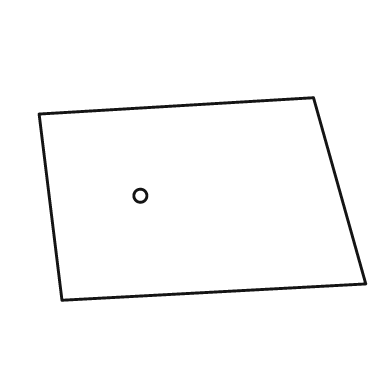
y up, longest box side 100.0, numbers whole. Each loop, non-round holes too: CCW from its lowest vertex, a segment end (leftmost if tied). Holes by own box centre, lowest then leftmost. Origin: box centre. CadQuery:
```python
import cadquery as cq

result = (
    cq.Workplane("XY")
    .moveTo(-43.0, -31.0)
    .lineTo(50.0, -26.0)
    .lineTo(34.0, 31.0)
    .lineTo(-50.0, 26.0)
    .close()
    .moveTo(-19.0, 1.0)
    .circle(2.0)
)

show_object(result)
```